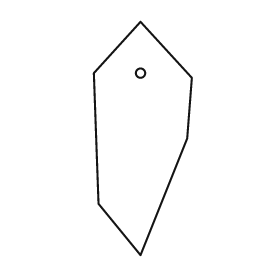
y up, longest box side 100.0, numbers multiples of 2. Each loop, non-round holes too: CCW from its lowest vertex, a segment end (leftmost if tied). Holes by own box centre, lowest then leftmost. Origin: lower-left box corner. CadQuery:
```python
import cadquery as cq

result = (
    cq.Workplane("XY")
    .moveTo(20.0, 0.0)
    .lineTo(40.0, 50.0)
    .lineTo(42.0, 76.0)
    .lineTo(20.0, 100.0)
    .lineTo(0.0, 78.0)
    .lineTo(2.0, 22.0)
    .close()
    .moveTo(20.0, 78.0)
    .circle(2.0)
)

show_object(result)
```